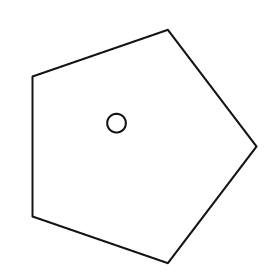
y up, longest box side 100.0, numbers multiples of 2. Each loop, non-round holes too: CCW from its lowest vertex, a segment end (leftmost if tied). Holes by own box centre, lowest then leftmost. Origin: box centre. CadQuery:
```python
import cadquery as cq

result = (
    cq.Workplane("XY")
    .moveTo(10.0, -50.0)
    .lineTo(48.0, 0.0)
    .lineTo(10.0, 50.0)
    .lineTo(-48.0, 30.0)
    .lineTo(-48.0, -30.0)
    .close()
    .moveTo(-12.0, 10.0)
    .circle(4.0)
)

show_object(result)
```